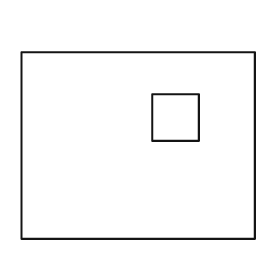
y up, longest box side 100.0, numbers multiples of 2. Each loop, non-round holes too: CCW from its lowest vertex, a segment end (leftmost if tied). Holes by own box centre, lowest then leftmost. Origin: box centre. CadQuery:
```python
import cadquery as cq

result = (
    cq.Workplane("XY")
    .moveTo(-50.0, -40.0)
    .lineTo(50.0, -40.0)
    .lineTo(50.0, 40.0)
    .lineTo(-50.0, 40.0)
    .close()
    .moveTo(6.0, 2.0)
    .lineTo(26.0, 2.0)
    .lineTo(26.0, 22.0)
    .lineTo(6.0, 22.0)
    .close()
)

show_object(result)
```